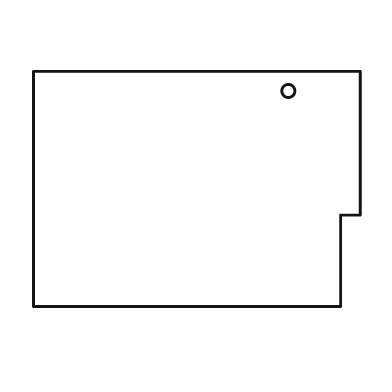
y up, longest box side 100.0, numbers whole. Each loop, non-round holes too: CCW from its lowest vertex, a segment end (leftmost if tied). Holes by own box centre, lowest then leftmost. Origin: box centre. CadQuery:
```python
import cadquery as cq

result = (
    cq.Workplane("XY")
    .moveTo(-50.0, -36.0)
    .lineTo(44.0, -36.0)
    .lineTo(44.0, -8.0)
    .lineTo(50.0, -8.0)
    .lineTo(50.0, 36.0)
    .lineTo(-50.0, 36.0)
    .close()
    .moveTo(28.0, 30.0)
    .circle(2.0)
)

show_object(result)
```